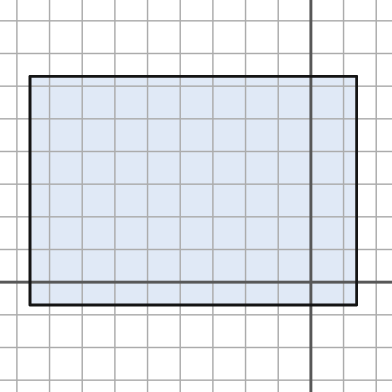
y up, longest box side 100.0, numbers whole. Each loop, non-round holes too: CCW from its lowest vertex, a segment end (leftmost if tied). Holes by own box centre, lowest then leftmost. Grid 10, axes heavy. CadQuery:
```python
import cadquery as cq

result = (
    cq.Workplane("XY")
    .moveTo(-86.0, -7.0)
    .lineTo(14.0, -7.0)
    .lineTo(14.0, 63.0)
    .lineTo(-86.0, 63.0)
    .close()
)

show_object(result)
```